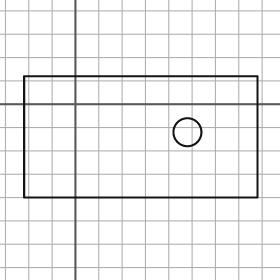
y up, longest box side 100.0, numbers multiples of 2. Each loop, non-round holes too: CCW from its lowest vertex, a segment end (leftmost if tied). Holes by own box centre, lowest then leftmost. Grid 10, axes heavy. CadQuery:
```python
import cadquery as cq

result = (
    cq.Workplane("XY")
    .moveTo(-22.0, -40.0)
    .lineTo(78.0, -40.0)
    .lineTo(78.0, 12.0)
    .lineTo(-22.0, 12.0)
    .close()
    .moveTo(48.0, -12.0)
    .circle(6.0)
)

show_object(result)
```